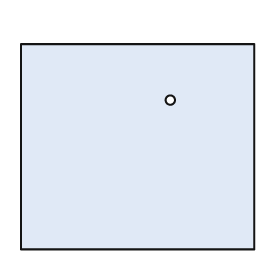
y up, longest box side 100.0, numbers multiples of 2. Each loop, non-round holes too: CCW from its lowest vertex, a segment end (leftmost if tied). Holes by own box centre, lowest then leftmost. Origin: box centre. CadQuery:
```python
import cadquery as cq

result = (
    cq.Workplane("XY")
    .moveTo(-50.0, -44.0)
    .lineTo(50.0, -44.0)
    .lineTo(50.0, 44.0)
    .lineTo(-50.0, 44.0)
    .close()
    .moveTo(14.0, 20.0)
    .circle(2.0)
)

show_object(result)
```